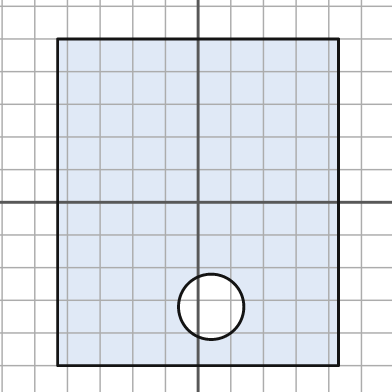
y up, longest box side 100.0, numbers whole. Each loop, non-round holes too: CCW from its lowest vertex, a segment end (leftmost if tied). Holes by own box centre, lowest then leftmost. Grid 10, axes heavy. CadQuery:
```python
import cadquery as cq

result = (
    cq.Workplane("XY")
    .moveTo(-43.0, -50.0)
    .lineTo(43.0, -50.0)
    .lineTo(43.0, 50.0)
    .lineTo(-43.0, 50.0)
    .close()
    .moveTo(4.0, -32.0)
    .circle(10.0)
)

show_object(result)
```